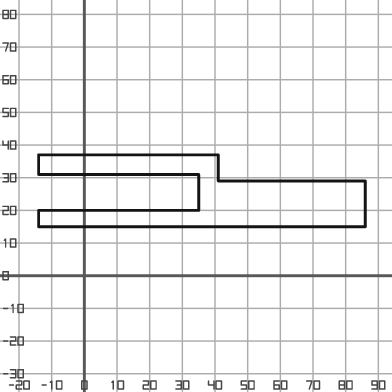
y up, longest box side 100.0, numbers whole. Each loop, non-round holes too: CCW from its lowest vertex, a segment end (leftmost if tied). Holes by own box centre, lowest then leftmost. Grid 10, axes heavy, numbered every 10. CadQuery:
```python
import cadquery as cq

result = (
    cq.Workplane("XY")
    .moveTo(-14.0, 15.0)
    .lineTo(86.0, 15.0)
    .lineTo(86.0, 29.0)
    .lineTo(41.0, 29.0)
    .lineTo(41.0, 37.0)
    .lineTo(-14.0, 37.0)
    .lineTo(-14.0, 31.0)
    .lineTo(35.0, 31.0)
    .lineTo(35.0, 20.0)
    .lineTo(-14.0, 20.0)
    .close()
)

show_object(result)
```